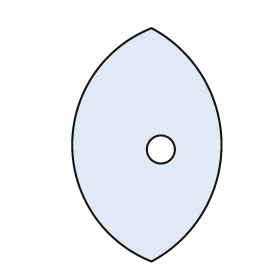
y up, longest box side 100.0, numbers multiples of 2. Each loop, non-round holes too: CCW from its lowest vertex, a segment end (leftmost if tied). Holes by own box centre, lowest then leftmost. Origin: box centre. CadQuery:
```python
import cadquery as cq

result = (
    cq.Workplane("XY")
    .moveTo(2.0, -50.0)
    .threePointArc((32.0, 0.0), (2.0, 50.0))
    .threePointArc((-32.0, 0.0), (2.0, -50.0))
    .close()
    .moveTo(6.0, -2.0)
    .circle(6.0)
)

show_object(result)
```